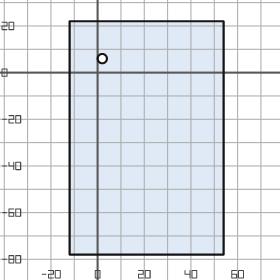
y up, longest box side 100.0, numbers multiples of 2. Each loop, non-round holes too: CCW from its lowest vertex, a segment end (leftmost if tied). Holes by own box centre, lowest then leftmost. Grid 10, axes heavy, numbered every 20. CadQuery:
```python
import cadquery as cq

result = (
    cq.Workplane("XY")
    .moveTo(-12.0, -78.0)
    .lineTo(54.0, -78.0)
    .lineTo(54.0, 22.0)
    .lineTo(-12.0, 22.0)
    .close()
    .moveTo(2.0, 6.0)
    .circle(2.0)
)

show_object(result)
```